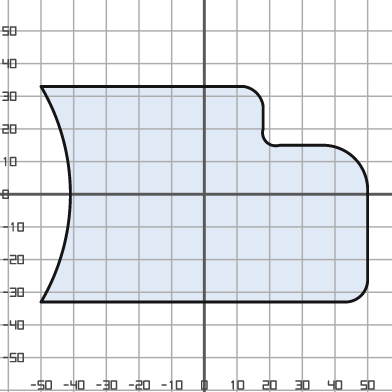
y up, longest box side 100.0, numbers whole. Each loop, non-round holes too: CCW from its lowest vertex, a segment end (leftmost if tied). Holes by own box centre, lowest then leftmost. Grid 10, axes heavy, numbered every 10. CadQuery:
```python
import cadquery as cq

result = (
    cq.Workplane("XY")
    .moveTo(-50.0, -33.0)
    .lineTo(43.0, -33.0)
    .threePointArc((48.0, -31.0), (50.0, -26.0))
    .lineTo(50.0, 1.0)
    .threePointArc((46.0, 11.0), (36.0, 15.0))
    .lineTo(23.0, 15.0)
    .threePointArc((19.0, 16.0), (18.0, 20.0))
    .lineTo(18.0, 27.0)
    .threePointArc((16.0, 31.0), (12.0, 33.0))
    .lineTo(-50.0, 33.0)
    .threePointArc((-41.0, 0.0), (-50.0, -33.0))
    .close()
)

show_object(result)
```